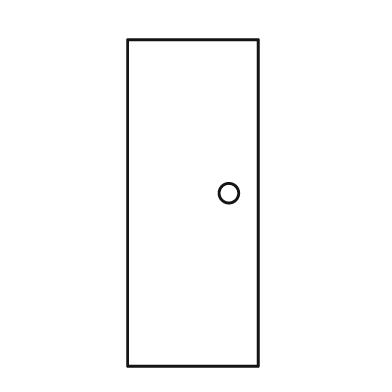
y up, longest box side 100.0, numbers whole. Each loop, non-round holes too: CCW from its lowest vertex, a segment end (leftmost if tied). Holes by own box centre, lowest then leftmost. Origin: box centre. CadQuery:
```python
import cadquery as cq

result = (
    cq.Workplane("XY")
    .moveTo(-20.0, -50.0)
    .lineTo(20.0, -50.0)
    .lineTo(20.0, 50.0)
    .lineTo(-20.0, 50.0)
    .close()
    .moveTo(11.0, 3.0)
    .circle(3.0)
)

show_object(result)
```